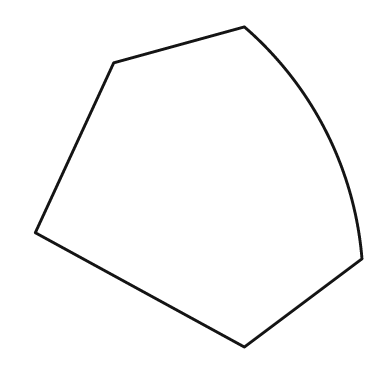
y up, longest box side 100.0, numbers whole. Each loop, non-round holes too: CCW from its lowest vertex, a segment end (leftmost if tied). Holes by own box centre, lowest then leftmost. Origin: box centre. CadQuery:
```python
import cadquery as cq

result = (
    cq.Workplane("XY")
    .moveTo(14.0, -49.0)
    .lineTo(50.0, -22.0)
    .threePointArc((39.0, 17.0), (14.0, 49.0))
    .lineTo(-26.0, 38.0)
    .lineTo(-50.0, -14.0)
    .close()
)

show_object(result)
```